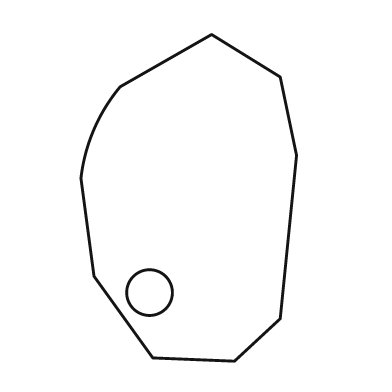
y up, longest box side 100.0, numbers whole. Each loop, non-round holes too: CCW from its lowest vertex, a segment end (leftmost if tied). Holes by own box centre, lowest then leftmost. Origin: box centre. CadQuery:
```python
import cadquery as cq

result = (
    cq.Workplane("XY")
    .moveTo(14.0, -50.0)
    .lineTo(28.0, -37.0)
    .lineTo(33.0, 13.0)
    .lineTo(28.0, 37.0)
    .lineTo(7.0, 50.0)
    .lineTo(-21.0, 34.0)
    .threePointArc((-29.0, 21.0), (-33.0, 6.0))
    .lineTo(-29.0, -24.0)
    .lineTo(-11.0, -49.0)
    .close()
    .moveTo(-12.0, -29.0)
    .circle(7.0)
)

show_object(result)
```